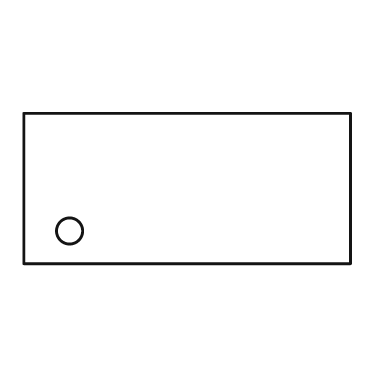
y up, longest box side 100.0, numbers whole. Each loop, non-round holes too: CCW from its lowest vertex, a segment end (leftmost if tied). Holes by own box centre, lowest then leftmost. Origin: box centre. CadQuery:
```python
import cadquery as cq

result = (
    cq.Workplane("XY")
    .moveTo(-50.0, -23.0)
    .lineTo(50.0, -23.0)
    .lineTo(50.0, 23.0)
    .lineTo(-50.0, 23.0)
    .close()
    .moveTo(-36.0, -13.0)
    .circle(4.0)
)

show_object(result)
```